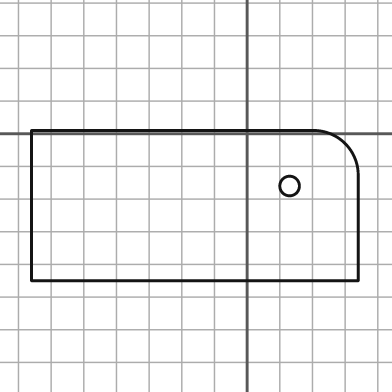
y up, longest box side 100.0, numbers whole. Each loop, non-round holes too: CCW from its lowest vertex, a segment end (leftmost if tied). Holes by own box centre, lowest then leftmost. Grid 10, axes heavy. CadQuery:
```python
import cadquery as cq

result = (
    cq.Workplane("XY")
    .moveTo(-66.0, -45.0)
    .lineTo(34.0, -45.0)
    .lineTo(34.0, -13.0)
    .threePointArc((30.0, -3.0), (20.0, 1.0))
    .lineTo(-66.0, 1.0)
    .close()
    .moveTo(13.0, -16.0)
    .circle(3.0)
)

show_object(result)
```